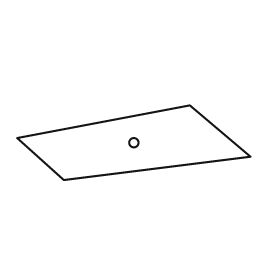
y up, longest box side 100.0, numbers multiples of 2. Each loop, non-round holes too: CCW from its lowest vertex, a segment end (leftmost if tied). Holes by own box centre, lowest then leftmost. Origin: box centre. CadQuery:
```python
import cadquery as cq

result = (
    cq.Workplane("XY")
    .moveTo(-30.0, -16.0)
    .lineTo(50.0, -6.0)
    .lineTo(24.0, 16.0)
    .lineTo(-50.0, 2.0)
    .close()
    .moveTo(0.0, 0.0)
    .circle(2.0)
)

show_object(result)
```